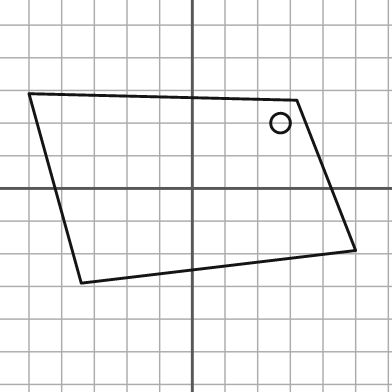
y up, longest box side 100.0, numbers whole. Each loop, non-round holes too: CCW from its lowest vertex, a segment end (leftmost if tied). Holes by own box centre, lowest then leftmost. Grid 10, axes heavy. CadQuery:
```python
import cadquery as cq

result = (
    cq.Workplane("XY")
    .moveTo(-34.0, -29.0)
    .lineTo(50.0, -19.0)
    .lineTo(32.0, 27.0)
    .lineTo(-50.0, 29.0)
    .close()
    .moveTo(27.0, 20.0)
    .circle(3.0)
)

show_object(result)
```